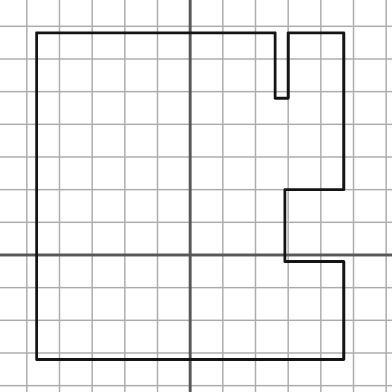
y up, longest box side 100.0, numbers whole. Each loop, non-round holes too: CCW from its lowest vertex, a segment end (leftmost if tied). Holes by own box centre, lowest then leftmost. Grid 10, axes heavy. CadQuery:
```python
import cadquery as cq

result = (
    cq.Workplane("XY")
    .moveTo(-47.0, -32.0)
    .lineTo(47.0, -32.0)
    .lineTo(47.0, -2.0)
    .lineTo(29.0, -2.0)
    .lineTo(29.0, 20.0)
    .lineTo(47.0, 20.0)
    .lineTo(47.0, 68.0)
    .lineTo(30.0, 68.0)
    .lineTo(30.0, 48.0)
    .lineTo(26.0, 48.0)
    .lineTo(26.0, 68.0)
    .lineTo(-47.0, 68.0)
    .close()
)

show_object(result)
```